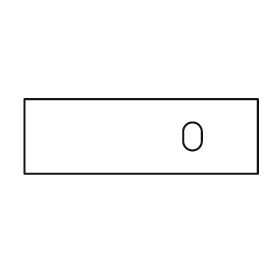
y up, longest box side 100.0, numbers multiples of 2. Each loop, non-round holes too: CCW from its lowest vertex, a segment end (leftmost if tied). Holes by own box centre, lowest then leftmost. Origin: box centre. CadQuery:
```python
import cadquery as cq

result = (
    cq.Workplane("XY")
    .moveTo(-50.0, -16.0)
    .lineTo(50.0, -16.0)
    .lineTo(50.0, 16.0)
    .lineTo(-50.0, 16.0)
    .close()
    .moveTo(18.0, -2.0)
    .threePointArc((22.0, -6.0), (26.0, -2.0))
    .lineTo(26.0, 2.0)
    .threePointArc((22.0, 6.0), (18.0, 2.0))
    .close()
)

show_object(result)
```